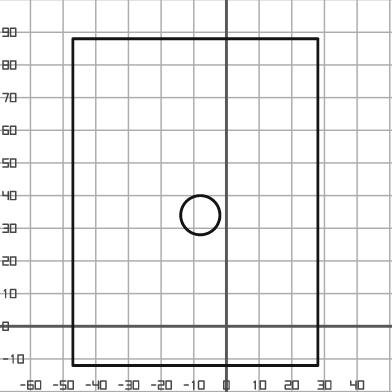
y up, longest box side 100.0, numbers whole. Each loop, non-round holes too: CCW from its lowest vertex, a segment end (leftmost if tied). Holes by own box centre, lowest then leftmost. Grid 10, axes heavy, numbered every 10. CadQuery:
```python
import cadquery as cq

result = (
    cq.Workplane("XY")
    .moveTo(-47.0, -12.0)
    .lineTo(28.0, -12.0)
    .lineTo(28.0, 88.0)
    .lineTo(-47.0, 88.0)
    .close()
    .moveTo(-8.0, 34.0)
    .circle(6.0)
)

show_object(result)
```